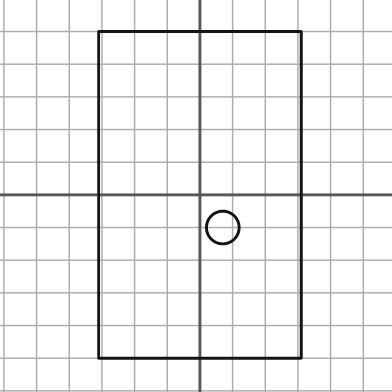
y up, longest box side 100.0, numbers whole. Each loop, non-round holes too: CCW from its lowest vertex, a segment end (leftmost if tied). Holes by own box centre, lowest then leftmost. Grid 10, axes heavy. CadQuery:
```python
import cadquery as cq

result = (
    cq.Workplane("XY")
    .moveTo(-31.0, -50.0)
    .lineTo(31.0, -50.0)
    .lineTo(31.0, 50.0)
    .lineTo(-31.0, 50.0)
    .close()
    .moveTo(7.0, -10.0)
    .circle(5.0)
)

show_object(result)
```